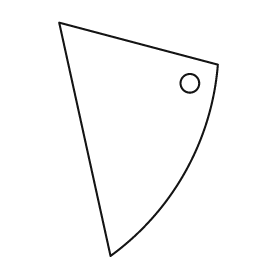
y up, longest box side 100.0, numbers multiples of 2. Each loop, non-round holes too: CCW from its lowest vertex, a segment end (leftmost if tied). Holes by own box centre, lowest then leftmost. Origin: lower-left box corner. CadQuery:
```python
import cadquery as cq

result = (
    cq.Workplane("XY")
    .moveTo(22.0, 0.0)
    .threePointArc((54.0, 36.0), (68.0, 82.0))
    .lineTo(0.0, 100.0)
    .close()
    .moveTo(56.0, 74.0)
    .circle(4.0)
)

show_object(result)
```